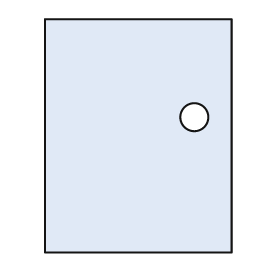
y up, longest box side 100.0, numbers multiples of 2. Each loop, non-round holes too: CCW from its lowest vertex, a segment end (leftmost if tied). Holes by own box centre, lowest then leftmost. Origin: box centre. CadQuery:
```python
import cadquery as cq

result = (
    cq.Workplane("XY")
    .moveTo(-40.0, -50.0)
    .lineTo(40.0, -50.0)
    .lineTo(40.0, 50.0)
    .lineTo(-40.0, 50.0)
    .close()
    .moveTo(24.0, 8.0)
    .circle(6.0)
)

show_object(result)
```